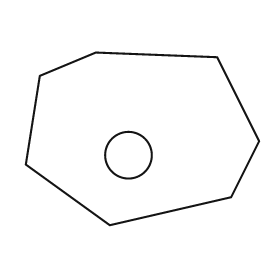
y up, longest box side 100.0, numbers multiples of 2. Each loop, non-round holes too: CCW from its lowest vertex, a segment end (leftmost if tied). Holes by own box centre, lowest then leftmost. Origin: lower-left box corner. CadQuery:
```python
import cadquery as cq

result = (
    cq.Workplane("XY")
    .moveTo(36.0, 0.0)
    .lineTo(88.0, 12.0)
    .lineTo(100.0, 36.0)
    .lineTo(82.0, 72.0)
    .lineTo(30.0, 74.0)
    .lineTo(6.0, 64.0)
    .lineTo(0.0, 26.0)
    .close()
    .moveTo(44.0, 30.0)
    .circle(10.0)
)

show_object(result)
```